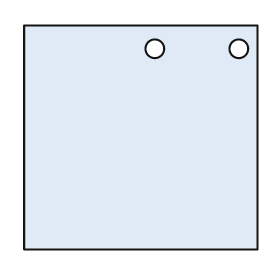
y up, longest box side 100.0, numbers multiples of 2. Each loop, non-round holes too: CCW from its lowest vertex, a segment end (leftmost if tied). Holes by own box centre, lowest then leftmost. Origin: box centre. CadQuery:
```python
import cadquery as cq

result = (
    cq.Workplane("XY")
    .moveTo(-50.0, -48.0)
    .lineTo(50.0, -48.0)
    .lineTo(50.0, 48.0)
    .lineTo(-50.0, 48.0)
    .close()
    .moveTo(6.0, 38.0)
    .circle(4.0)
    .moveTo(42.0, 38.0)
    .circle(4.0)
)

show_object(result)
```